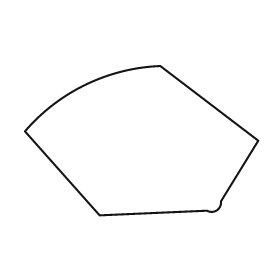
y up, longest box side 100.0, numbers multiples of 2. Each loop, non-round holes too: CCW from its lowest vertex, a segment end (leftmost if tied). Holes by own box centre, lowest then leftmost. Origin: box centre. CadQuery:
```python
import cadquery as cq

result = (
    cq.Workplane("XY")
    .moveTo(-18.0, -32.0)
    .lineTo(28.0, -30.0)
    .threePointArc((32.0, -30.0), (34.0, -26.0))
    .lineTo(50.0, 0.0)
    .lineTo(8.0, 32.0)
    .threePointArc((-24.0, 24.0), (-50.0, 4.0))
    .close()
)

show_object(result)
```